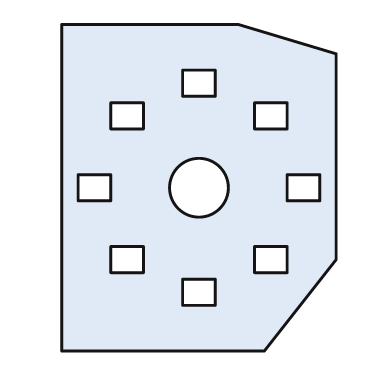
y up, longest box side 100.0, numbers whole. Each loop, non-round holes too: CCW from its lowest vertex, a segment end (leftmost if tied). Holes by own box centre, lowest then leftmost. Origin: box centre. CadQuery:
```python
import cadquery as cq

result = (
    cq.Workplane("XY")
    .moveTo(-42.0, -50.0)
    .lineTo(20.0, -50.0)
    .lineTo(42.0, -22.0)
    .lineTo(42.0, 41.0)
    .lineTo(12.0, 50.0)
    .lineTo(-42.0, 50.0)
    .close()
    .moveTo(-5.0, -36.0)
    .lineTo(5.0, -36.0)
    .lineTo(5.0, -28.0)
    .lineTo(-5.0, -28.0)
    .close()
    .moveTo(-27.0, -26.0)
    .lineTo(-17.0, -26.0)
    .lineTo(-17.0, -18.0)
    .lineTo(-27.0, -18.0)
    .close()
    .moveTo(17.0, -26.0)
    .lineTo(27.0, -26.0)
    .lineTo(27.0, -18.0)
    .lineTo(17.0, -18.0)
    .close()
    .moveTo(-37.0, -4.0)
    .lineTo(-27.0, -4.0)
    .lineTo(-27.0, 4.0)
    .lineTo(-37.0, 4.0)
    .close()
    .moveTo(0.0, 0.0)
    .circle(9.0)
    .moveTo(27.0, -4.0)
    .lineTo(37.0, -4.0)
    .lineTo(37.0, 4.0)
    .lineTo(27.0, 4.0)
    .close()
    .moveTo(-27.0, 18.0)
    .lineTo(-17.0, 18.0)
    .lineTo(-17.0, 26.0)
    .lineTo(-27.0, 26.0)
    .close()
    .moveTo(17.0, 18.0)
    .lineTo(27.0, 18.0)
    .lineTo(27.0, 26.0)
    .lineTo(17.0, 26.0)
    .close()
    .moveTo(-5.0, 28.0)
    .lineTo(5.0, 28.0)
    .lineTo(5.0, 36.0)
    .lineTo(-5.0, 36.0)
    .close()
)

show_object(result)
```